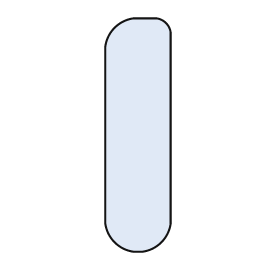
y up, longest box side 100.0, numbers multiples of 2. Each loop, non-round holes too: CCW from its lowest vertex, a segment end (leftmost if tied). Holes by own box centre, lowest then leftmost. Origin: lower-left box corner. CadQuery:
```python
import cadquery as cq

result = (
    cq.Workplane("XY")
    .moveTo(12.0, 0.0)
    .lineTo(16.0, 0.0)
    .threePointArc((24.0, 4.0), (28.0, 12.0))
    .lineTo(28.0, 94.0)
    .threePointArc((26.0, 98.0), (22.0, 100.0))
    .lineTo(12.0, 100.0)
    .threePointArc((4.0, 96.0), (0.0, 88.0))
    .lineTo(0.0, 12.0)
    .threePointArc((4.0, 4.0), (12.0, 0.0))
    .close()
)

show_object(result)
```